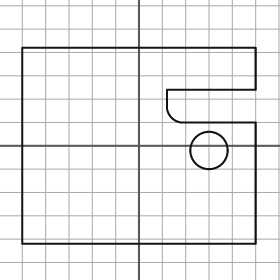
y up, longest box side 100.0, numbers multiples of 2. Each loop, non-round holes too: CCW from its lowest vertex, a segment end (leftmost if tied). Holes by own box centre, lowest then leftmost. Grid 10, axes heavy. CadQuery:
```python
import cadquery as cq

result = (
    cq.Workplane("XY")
    .moveTo(-50.0, -42.0)
    .lineTo(50.0, -42.0)
    .lineTo(50.0, 10.0)
    .lineTo(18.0, 10.0)
    .threePointArc((14.0, 12.0), (12.0, 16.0))
    .lineTo(12.0, 24.0)
    .lineTo(50.0, 24.0)
    .lineTo(50.0, 42.0)
    .lineTo(-50.0, 42.0)
    .close()
    .moveTo(30.0, -2.0)
    .circle(8.0)
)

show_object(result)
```